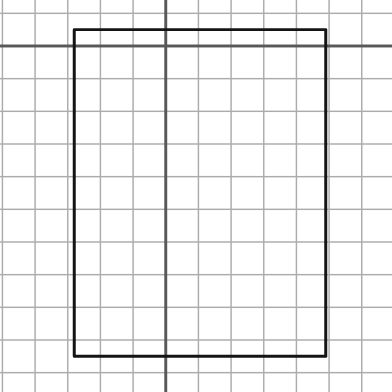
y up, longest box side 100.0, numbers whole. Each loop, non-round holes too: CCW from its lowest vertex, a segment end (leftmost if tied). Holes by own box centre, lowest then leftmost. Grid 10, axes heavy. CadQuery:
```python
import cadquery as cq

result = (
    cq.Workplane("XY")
    .moveTo(-28.0, -95.0)
    .lineTo(49.0, -95.0)
    .lineTo(49.0, 5.0)
    .lineTo(-28.0, 5.0)
    .close()
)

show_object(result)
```